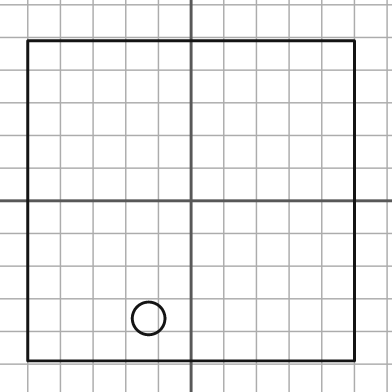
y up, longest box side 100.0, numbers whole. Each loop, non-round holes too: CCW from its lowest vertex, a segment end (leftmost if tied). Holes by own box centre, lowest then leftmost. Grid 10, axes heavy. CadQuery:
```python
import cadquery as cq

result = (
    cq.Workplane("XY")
    .moveTo(-50.0, -49.0)
    .lineTo(50.0, -49.0)
    .lineTo(50.0, 49.0)
    .lineTo(-50.0, 49.0)
    .close()
    .moveTo(-13.0, -36.0)
    .circle(5.0)
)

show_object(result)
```